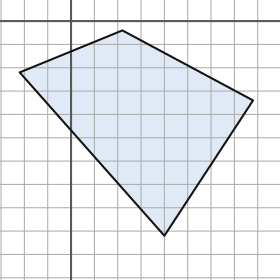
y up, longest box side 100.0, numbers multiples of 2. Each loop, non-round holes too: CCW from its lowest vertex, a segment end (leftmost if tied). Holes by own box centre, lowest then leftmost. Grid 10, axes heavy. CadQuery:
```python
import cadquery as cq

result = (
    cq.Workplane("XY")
    .moveTo(40.0, -92.0)
    .lineTo(78.0, -34.0)
    .lineTo(22.0, -4.0)
    .lineTo(-22.0, -22.0)
    .close()
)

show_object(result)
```